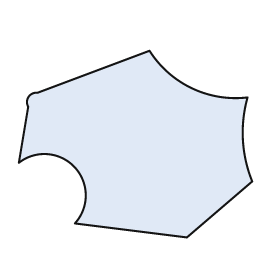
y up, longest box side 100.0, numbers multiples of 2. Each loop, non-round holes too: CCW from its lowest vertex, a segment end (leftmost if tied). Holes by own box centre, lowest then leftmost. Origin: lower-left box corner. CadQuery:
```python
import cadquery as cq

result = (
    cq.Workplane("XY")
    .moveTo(72.0, 0.0)
    .lineTo(100.0, 24.0)
    .threePointArc((96.0, 42.0), (98.0, 60.0))
    .threePointArc((74.0, 64.0), (56.0, 80.0))
    .lineTo(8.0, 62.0)
    .threePointArc((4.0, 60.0), (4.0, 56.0))
    .lineTo(0.0, 32.0)
    .threePointArc((24.0, 30.0), (24.0, 6.0))
    .close()
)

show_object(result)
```